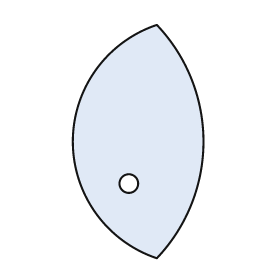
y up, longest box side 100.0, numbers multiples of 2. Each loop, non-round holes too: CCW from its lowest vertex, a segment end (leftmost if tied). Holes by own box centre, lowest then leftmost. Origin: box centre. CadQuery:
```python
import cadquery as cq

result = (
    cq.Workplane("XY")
    .moveTo(8.0, -50.0)
    .threePointArc((28.0, 0.0), (8.0, 50.0))
    .threePointArc((-28.0, 0.0), (8.0, -50.0))
    .close()
    .moveTo(-4.0, -18.0)
    .circle(4.0)
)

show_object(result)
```